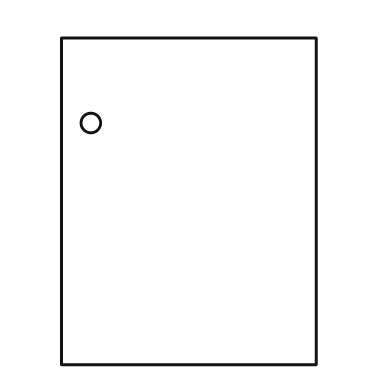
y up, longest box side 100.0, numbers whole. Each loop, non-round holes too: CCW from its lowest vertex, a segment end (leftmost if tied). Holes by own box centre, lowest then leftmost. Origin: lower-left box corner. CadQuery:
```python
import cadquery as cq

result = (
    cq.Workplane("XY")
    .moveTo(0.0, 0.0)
    .lineTo(78.0, 0.0)
    .lineTo(78.0, 100.0)
    .lineTo(0.0, 100.0)
    .close()
    .moveTo(9.0, 74.0)
    .circle(3.0)
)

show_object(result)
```